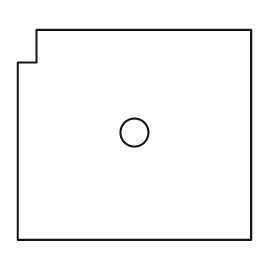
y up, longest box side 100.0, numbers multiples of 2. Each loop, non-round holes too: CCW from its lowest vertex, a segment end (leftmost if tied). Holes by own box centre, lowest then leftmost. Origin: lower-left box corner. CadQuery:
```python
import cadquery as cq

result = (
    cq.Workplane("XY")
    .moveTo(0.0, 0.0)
    .lineTo(100.0, 0.0)
    .lineTo(100.0, 90.0)
    .lineTo(8.0, 90.0)
    .lineTo(8.0, 76.0)
    .lineTo(0.0, 76.0)
    .close()
    .moveTo(50.0, 46.0)
    .circle(6.0)
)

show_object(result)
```